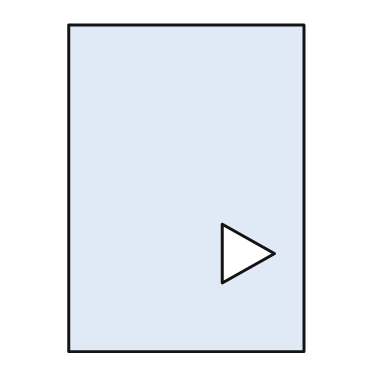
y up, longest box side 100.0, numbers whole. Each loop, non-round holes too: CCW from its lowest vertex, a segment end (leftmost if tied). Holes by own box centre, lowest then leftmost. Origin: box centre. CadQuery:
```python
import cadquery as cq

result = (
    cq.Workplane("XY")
    .moveTo(-36.0, -50.0)
    .lineTo(36.0, -50.0)
    .lineTo(36.0, 50.0)
    .lineTo(-36.0, 50.0)
    .close()
    .moveTo(11.0, -29.0)
    .lineTo(27.0, -20.0)
    .lineTo(11.0, -11.0)
    .close()
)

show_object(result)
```